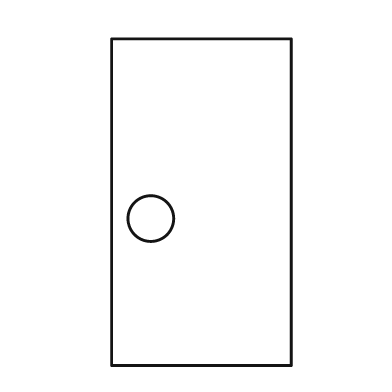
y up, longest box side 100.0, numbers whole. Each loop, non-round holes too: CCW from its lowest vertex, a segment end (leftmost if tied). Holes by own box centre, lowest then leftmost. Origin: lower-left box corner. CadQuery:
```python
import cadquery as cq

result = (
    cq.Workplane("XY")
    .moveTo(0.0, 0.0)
    .lineTo(55.0, 0.0)
    .lineTo(55.0, 100.0)
    .lineTo(0.0, 100.0)
    .close()
    .moveTo(12.0, 45.0)
    .circle(7.0)
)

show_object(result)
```